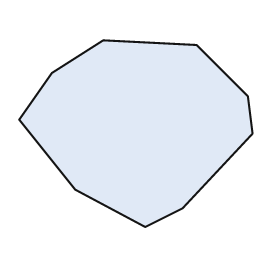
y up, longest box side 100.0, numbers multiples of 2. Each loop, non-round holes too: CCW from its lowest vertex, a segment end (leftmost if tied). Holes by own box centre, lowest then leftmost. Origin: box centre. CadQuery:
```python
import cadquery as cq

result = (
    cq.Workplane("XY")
    .moveTo(4.0, -40.0)
    .lineTo(20.0, -32.0)
    .lineTo(50.0, 0.0)
    .lineTo(48.0, 16.0)
    .lineTo(26.0, 38.0)
    .lineTo(-14.0, 40.0)
    .lineTo(-36.0, 26.0)
    .lineTo(-50.0, 6.0)
    .lineTo(-26.0, -24.0)
    .close()
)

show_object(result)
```